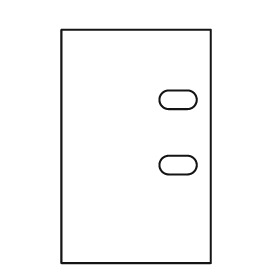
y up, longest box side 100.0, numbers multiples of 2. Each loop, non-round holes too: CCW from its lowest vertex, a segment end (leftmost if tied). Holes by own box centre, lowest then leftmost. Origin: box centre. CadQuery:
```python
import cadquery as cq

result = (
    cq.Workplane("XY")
    .moveTo(-32.0, -50.0)
    .lineTo(32.0, -50.0)
    .lineTo(32.0, 50.0)
    .lineTo(-32.0, 50.0)
    .close()
    .moveTo(14.0, -12.0)
    .lineTo(22.0, -12.0)
    .threePointArc((26.0, -8.0), (22.0, -4.0))
    .lineTo(14.0, -4.0)
    .threePointArc((10.0, -8.0), (14.0, -12.0))
    .close()
    .moveTo(14.0, 16.0)
    .lineTo(22.0, 16.0)
    .threePointArc((26.0, 20.0), (22.0, 24.0))
    .lineTo(14.0, 24.0)
    .threePointArc((10.0, 20.0), (14.0, 16.0))
    .close()
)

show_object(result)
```